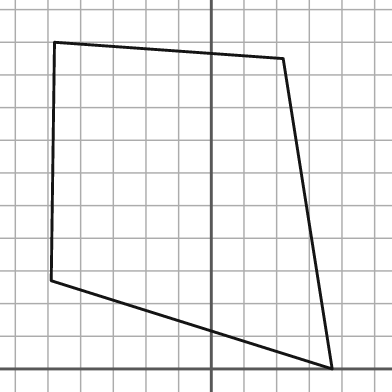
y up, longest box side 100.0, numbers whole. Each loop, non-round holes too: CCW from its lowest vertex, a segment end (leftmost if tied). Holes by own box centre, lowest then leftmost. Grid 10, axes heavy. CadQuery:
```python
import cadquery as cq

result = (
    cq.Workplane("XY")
    .moveTo(37.0, 0.0)
    .lineTo(22.0, 95.0)
    .lineTo(-48.0, 100.0)
    .lineTo(-49.0, 27.0)
    .close()
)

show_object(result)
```